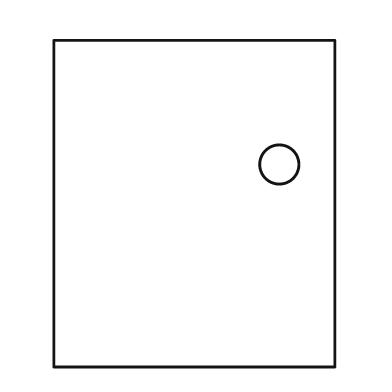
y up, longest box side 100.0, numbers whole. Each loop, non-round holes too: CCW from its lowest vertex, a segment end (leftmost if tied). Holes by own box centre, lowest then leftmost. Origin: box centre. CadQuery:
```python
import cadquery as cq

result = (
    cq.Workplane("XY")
    .moveTo(-43.0, -50.0)
    .lineTo(43.0, -50.0)
    .lineTo(43.0, 50.0)
    .lineTo(-43.0, 50.0)
    .close()
    .moveTo(26.0, 12.0)
    .circle(6.0)
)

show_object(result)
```